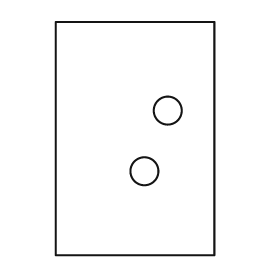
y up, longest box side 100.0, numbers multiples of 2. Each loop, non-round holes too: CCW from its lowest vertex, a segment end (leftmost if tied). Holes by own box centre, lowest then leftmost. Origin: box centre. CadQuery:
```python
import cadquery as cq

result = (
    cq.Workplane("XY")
    .moveTo(-34.0, -50.0)
    .lineTo(34.0, -50.0)
    .lineTo(34.0, 50.0)
    .lineTo(-34.0, 50.0)
    .close()
    .moveTo(4.0, -14.0)
    .circle(6.0)
    .moveTo(14.0, 12.0)
    .circle(6.0)
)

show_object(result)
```